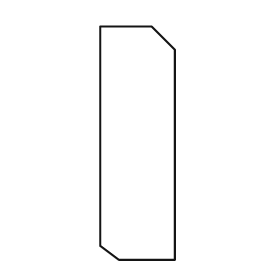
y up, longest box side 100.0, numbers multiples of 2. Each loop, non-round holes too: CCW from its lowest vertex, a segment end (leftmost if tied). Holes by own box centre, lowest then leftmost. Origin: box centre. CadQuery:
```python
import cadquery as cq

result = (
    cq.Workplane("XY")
    .moveTo(-8.0, -50.0)
    .lineTo(16.0, -50.0)
    .lineTo(16.0, 40.0)
    .lineTo(6.0, 50.0)
    .lineTo(-16.0, 50.0)
    .lineTo(-16.0, -44.0)
    .close()
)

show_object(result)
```